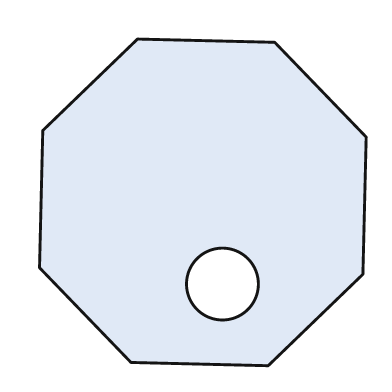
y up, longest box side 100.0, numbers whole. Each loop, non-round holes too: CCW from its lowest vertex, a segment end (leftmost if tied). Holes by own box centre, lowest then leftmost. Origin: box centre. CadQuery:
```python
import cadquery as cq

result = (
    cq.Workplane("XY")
    .moveTo(20.0, -50.0)
    .lineTo(49.0, -22.0)
    .lineTo(50.0, 20.0)
    .lineTo(22.0, 49.0)
    .lineTo(-20.0, 50.0)
    .lineTo(-49.0, 22.0)
    .lineTo(-50.0, -20.0)
    .lineTo(-22.0, -49.0)
    .close()
    .moveTo(6.0, -25.0)
    .circle(11.0)
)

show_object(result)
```